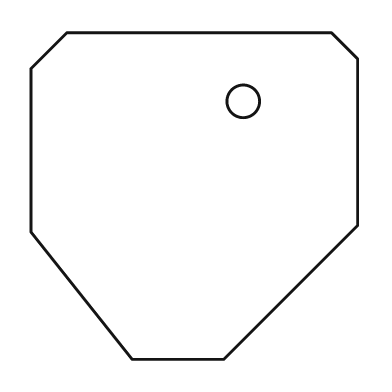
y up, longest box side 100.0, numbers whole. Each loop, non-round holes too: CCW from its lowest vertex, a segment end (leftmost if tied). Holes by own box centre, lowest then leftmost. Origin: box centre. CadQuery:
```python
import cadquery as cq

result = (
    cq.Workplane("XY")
    .moveTo(-19.0, -50.0)
    .lineTo(9.0, -50.0)
    .lineTo(50.0, -9.0)
    .lineTo(50.0, 42.0)
    .lineTo(42.0, 50.0)
    .lineTo(-39.0, 50.0)
    .lineTo(-50.0, 39.0)
    .lineTo(-50.0, -11.0)
    .close()
    .moveTo(15.0, 29.0)
    .circle(5.0)
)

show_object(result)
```